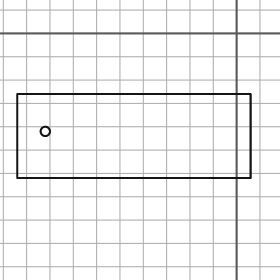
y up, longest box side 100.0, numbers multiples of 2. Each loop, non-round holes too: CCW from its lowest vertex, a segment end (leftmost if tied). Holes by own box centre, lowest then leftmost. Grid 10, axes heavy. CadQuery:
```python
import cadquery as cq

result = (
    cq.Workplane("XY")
    .moveTo(-94.0, -62.0)
    .lineTo(6.0, -62.0)
    .lineTo(6.0, -26.0)
    .lineTo(-94.0, -26.0)
    .close()
    .moveTo(-82.0, -42.0)
    .circle(2.0)
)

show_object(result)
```